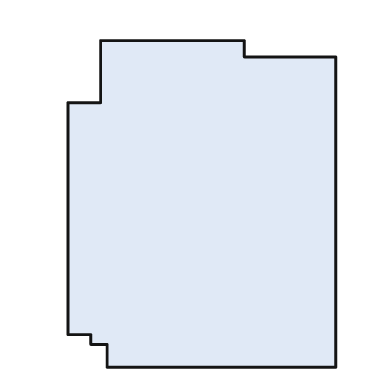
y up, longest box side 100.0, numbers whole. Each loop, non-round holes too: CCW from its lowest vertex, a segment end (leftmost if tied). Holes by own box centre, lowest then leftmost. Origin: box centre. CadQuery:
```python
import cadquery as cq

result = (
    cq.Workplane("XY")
    .moveTo(-29.0, -50.0)
    .lineTo(41.0, -50.0)
    .lineTo(41.0, 45.0)
    .lineTo(13.0, 45.0)
    .lineTo(13.0, 50.0)
    .lineTo(-31.0, 50.0)
    .lineTo(-31.0, 31.0)
    .lineTo(-41.0, 31.0)
    .lineTo(-41.0, -40.0)
    .lineTo(-34.0, -40.0)
    .lineTo(-34.0, -43.0)
    .lineTo(-29.0, -43.0)
    .close()
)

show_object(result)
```